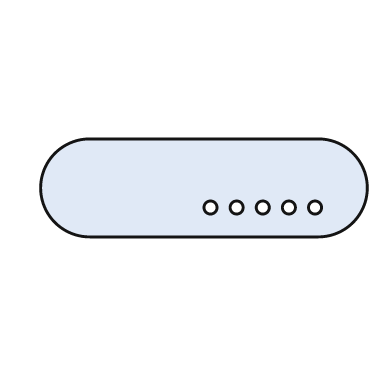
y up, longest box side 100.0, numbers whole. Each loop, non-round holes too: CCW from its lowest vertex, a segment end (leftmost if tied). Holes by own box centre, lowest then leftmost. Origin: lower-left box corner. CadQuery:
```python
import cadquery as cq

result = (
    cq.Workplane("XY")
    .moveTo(15.0, 0.0)
    .lineTo(85.0, 0.0)
    .threePointArc((100.0, 15.0), (85.0, 30.0))
    .lineTo(15.0, 30.0)
    .threePointArc((0.0, 15.0), (15.0, 0.0))
    .close()
    .moveTo(52.0, 9.0)
    .circle(2.0)
    .moveTo(60.0, 9.0)
    .circle(2.0)
    .moveTo(68.0, 9.0)
    .circle(2.0)
    .moveTo(76.0, 9.0)
    .circle(2.0)
    .moveTo(84.0, 9.0)
    .circle(2.0)
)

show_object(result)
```